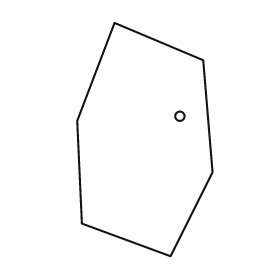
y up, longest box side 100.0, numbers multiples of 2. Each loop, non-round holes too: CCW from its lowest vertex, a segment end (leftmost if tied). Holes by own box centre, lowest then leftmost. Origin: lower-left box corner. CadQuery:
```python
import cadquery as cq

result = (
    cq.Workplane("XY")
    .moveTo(40.0, 0.0)
    .lineTo(58.0, 36.0)
    .lineTo(54.0, 84.0)
    .lineTo(16.0, 100.0)
    .lineTo(0.0, 58.0)
    .lineTo(2.0, 14.0)
    .close()
    .moveTo(44.0, 60.0)
    .circle(2.0)
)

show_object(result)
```